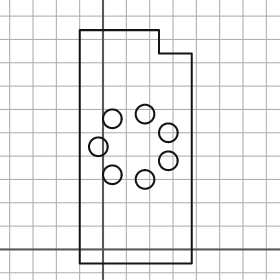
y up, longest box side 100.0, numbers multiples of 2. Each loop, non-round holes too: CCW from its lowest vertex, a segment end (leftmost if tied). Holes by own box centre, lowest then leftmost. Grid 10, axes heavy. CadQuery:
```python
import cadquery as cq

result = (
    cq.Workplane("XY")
    .moveTo(-10.0, -6.0)
    .lineTo(38.0, -6.0)
    .lineTo(38.0, 84.0)
    .lineTo(24.0, 84.0)
    .lineTo(24.0, 94.0)
    .lineTo(-10.0, 94.0)
    .close()
    .moveTo(18.0, 30.0)
    .circle(4.0)
    .moveTo(4.0, 32.0)
    .circle(4.0)
    .moveTo(28.0, 38.0)
    .circle(4.0)
    .moveTo(-2.0, 44.0)
    .circle(4.0)
    .moveTo(28.0, 50.0)
    .circle(4.0)
    .moveTo(4.0, 56.0)
    .circle(4.0)
    .moveTo(18.0, 58.0)
    .circle(4.0)
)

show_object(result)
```